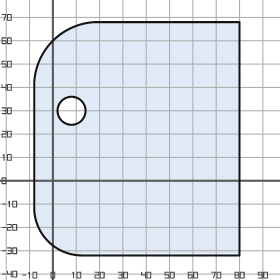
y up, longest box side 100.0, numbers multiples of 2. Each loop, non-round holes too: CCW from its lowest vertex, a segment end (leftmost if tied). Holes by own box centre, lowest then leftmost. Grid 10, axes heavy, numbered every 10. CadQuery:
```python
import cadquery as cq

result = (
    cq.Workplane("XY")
    .moveTo(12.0, -32.0)
    .lineTo(80.0, -32.0)
    .lineTo(80.0, 68.0)
    .lineTo(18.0, 68.0)
    .threePointArc((0.0, 60.0), (-8.0, 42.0))
    .lineTo(-8.0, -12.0)
    .threePointArc((-2.0, -26.0), (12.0, -32.0))
    .close()
    .moveTo(8.0, 30.0)
    .circle(6.0)
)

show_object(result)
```